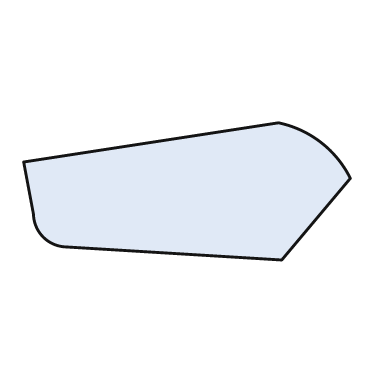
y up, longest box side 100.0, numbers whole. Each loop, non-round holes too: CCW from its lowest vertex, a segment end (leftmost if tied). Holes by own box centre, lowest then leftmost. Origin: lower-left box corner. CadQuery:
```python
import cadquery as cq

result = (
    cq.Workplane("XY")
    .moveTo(79.0, 0.0)
    .lineTo(100.0, 25.0)
    .threePointArc((91.0, 36.0), (78.0, 42.0))
    .lineTo(0.0, 30.0)
    .lineTo(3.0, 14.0)
    .threePointArc((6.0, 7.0), (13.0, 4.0))
    .close()
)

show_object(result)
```